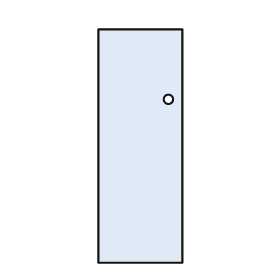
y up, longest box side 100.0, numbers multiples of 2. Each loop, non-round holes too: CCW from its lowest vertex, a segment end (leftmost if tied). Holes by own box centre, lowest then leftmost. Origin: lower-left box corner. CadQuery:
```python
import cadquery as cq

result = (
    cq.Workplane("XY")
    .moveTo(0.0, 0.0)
    .lineTo(36.0, 0.0)
    .lineTo(36.0, 100.0)
    .lineTo(0.0, 100.0)
    .close()
    .moveTo(30.0, 70.0)
    .circle(2.0)
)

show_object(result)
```